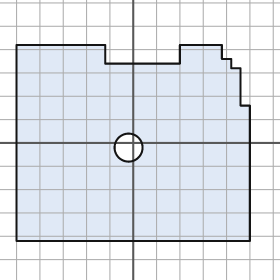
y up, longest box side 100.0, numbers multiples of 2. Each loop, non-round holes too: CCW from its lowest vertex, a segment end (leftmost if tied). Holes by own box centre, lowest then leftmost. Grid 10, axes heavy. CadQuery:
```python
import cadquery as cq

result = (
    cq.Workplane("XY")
    .moveTo(-50.0, -42.0)
    .lineTo(50.0, -42.0)
    .lineTo(50.0, 16.0)
    .lineTo(46.0, 16.0)
    .lineTo(46.0, 32.0)
    .lineTo(42.0, 32.0)
    .lineTo(42.0, 36.0)
    .lineTo(38.0, 36.0)
    .lineTo(38.0, 42.0)
    .lineTo(20.0, 42.0)
    .lineTo(20.0, 34.0)
    .lineTo(-12.0, 34.0)
    .lineTo(-12.0, 42.0)
    .lineTo(-50.0, 42.0)
    .close()
    .moveTo(-2.0, -2.0)
    .circle(6.0)
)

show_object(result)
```